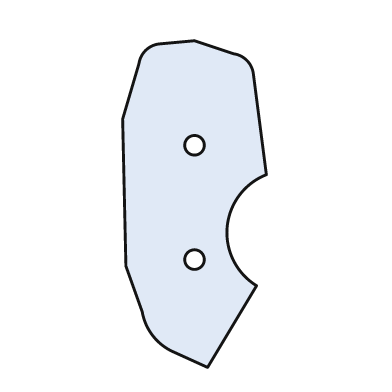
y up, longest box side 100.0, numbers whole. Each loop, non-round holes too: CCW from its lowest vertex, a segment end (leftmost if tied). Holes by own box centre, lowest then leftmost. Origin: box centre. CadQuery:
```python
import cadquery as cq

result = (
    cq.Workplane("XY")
    .moveTo(4.0, -50.0)
    .lineTo(19.0, -25.0)
    .threePointArc((10.0, -7.0), (22.0, 9.0))
    .lineTo(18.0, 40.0)
    .threePointArc((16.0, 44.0), (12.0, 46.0))
    .lineTo(0.0, 50.0)
    .lineTo(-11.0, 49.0)
    .threePointArc((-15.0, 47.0), (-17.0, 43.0))
    .lineTo(-22.0, 26.0)
    .lineTo(-21.0, -19.0)
    .lineTo(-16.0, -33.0)
    .threePointArc((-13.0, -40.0), (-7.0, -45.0))
    .close()
    .moveTo(0.0, -17.0)
    .circle(3.0)
    .moveTo(0.0, 18.0)
    .circle(3.0)
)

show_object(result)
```